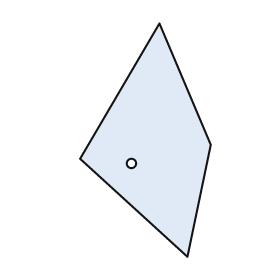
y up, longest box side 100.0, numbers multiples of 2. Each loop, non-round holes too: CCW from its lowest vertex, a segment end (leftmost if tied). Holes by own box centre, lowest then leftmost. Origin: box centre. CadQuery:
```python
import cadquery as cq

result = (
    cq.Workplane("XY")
    .moveTo(18.0, -50.0)
    .lineTo(28.0, -2.0)
    .lineTo(6.0, 50.0)
    .lineTo(-28.0, -8.0)
    .close()
    .moveTo(-6.0, -10.0)
    .circle(2.0)
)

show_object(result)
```